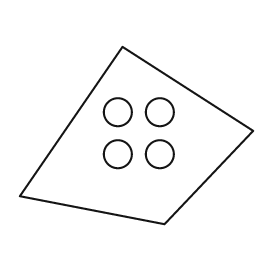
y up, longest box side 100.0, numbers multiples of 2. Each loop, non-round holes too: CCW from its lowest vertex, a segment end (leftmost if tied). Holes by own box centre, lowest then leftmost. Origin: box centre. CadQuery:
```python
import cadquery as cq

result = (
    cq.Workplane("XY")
    .moveTo(12.0, -38.0)
    .lineTo(50.0, 2.0)
    .lineTo(-6.0, 38.0)
    .lineTo(-50.0, -26.0)
    .close()
    .moveTo(-8.0, -8.0)
    .circle(6.0)
    .moveTo(10.0, -8.0)
    .circle(6.0)
    .moveTo(-8.0, 10.0)
    .circle(6.0)
    .moveTo(10.0, 10.0)
    .circle(6.0)
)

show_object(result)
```